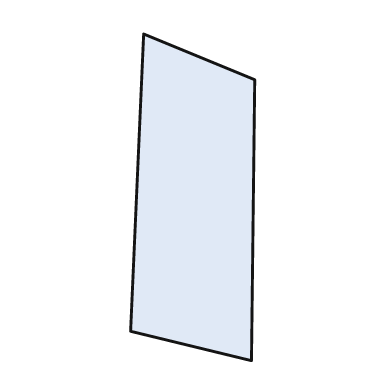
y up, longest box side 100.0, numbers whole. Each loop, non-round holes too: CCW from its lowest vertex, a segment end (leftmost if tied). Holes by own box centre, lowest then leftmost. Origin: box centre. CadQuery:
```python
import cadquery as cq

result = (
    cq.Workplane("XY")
    .moveTo(18.0, -50.0)
    .lineTo(19.0, 36.0)
    .lineTo(-15.0, 50.0)
    .lineTo(-19.0, -41.0)
    .close()
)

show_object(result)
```